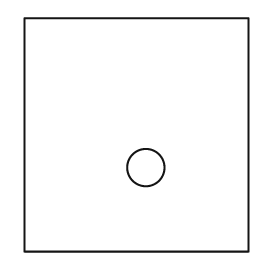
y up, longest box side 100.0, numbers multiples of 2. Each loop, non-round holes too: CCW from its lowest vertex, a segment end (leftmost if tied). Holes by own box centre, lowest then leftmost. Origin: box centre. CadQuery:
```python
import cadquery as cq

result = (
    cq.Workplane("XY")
    .moveTo(-48.0, -50.0)
    .lineTo(48.0, -50.0)
    .lineTo(48.0, 50.0)
    .lineTo(-48.0, 50.0)
    .close()
    .moveTo(4.0, -14.0)
    .circle(8.0)
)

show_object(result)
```